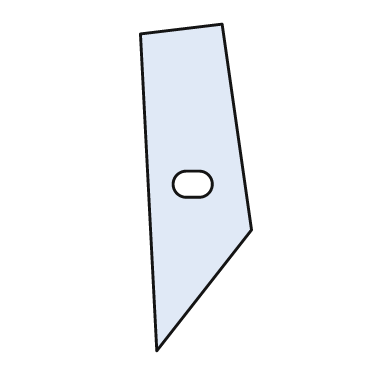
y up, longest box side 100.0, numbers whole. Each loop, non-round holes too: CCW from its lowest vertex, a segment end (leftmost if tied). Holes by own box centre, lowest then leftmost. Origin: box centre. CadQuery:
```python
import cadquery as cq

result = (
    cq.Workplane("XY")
    .moveTo(-12.0, -50.0)
    .lineTo(17.0, -13.0)
    .lineTo(8.0, 50.0)
    .lineTo(-17.0, 47.0)
    .close()
    .moveTo(-3.0, -3.0)
    .lineTo(1.0, -3.0)
    .threePointArc((5.0, 1.0), (1.0, 5.0))
    .lineTo(-3.0, 5.0)
    .threePointArc((-7.0, 1.0), (-3.0, -3.0))
    .close()
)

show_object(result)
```